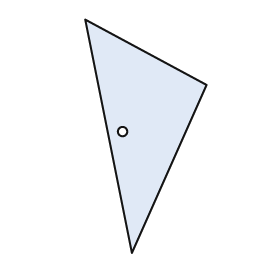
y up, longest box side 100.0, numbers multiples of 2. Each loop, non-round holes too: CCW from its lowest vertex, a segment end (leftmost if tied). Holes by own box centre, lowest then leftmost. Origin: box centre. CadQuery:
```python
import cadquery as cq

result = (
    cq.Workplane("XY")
    .moveTo(-6.0, -50.0)
    .lineTo(26.0, 22.0)
    .lineTo(-26.0, 50.0)
    .close()
    .moveTo(-10.0, 2.0)
    .circle(2.0)
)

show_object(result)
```